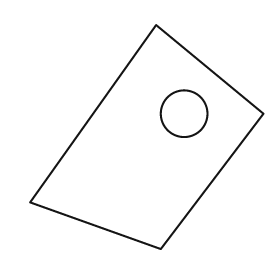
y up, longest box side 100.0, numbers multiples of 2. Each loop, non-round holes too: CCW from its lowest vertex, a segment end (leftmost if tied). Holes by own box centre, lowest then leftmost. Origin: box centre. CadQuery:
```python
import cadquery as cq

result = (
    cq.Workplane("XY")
    .moveTo(6.0, -48.0)
    .lineTo(50.0, 10.0)
    .lineTo(4.0, 48.0)
    .lineTo(-50.0, -28.0)
    .close()
    .moveTo(16.0, 10.0)
    .circle(10.0)
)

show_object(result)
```